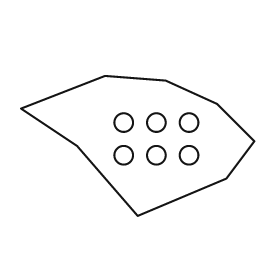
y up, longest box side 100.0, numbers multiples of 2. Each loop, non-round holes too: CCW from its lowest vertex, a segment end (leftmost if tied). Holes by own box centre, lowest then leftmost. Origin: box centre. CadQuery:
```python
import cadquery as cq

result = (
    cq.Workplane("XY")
    .moveTo(0.0, -30.0)
    .lineTo(38.0, -14.0)
    .lineTo(50.0, 2.0)
    .lineTo(34.0, 18.0)
    .lineTo(12.0, 28.0)
    .lineTo(-14.0, 30.0)
    .lineTo(-50.0, 16.0)
    .lineTo(-26.0, 0.0)
    .close()
    .moveTo(-6.0, -4.0)
    .circle(4.0)
    .moveTo(8.0, -4.0)
    .circle(4.0)
    .moveTo(22.0, -4.0)
    .circle(4.0)
    .moveTo(-6.0, 10.0)
    .circle(4.0)
    .moveTo(8.0, 10.0)
    .circle(4.0)
    .moveTo(22.0, 10.0)
    .circle(4.0)
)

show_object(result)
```